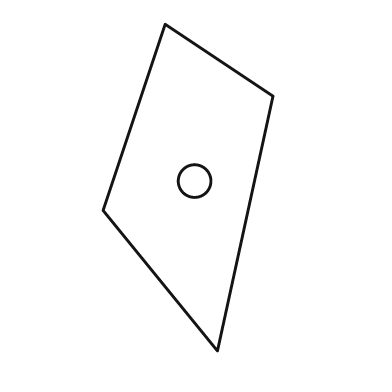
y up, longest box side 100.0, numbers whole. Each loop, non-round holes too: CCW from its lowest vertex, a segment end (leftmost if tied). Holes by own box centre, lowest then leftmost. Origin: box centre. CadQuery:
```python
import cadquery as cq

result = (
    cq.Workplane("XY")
    .moveTo(9.0, -50.0)
    .lineTo(26.0, 28.0)
    .lineTo(-7.0, 50.0)
    .lineTo(-26.0, -7.0)
    .close()
    .moveTo(2.0, 2.0)
    .circle(5.0)
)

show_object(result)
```